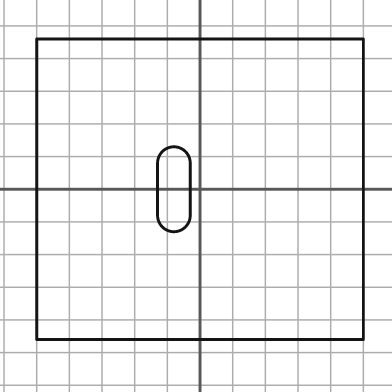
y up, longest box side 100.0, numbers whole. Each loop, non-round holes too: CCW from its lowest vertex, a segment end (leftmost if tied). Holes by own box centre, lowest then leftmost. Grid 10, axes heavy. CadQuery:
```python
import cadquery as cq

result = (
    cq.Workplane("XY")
    .moveTo(-50.0, -46.0)
    .lineTo(50.0, -46.0)
    .lineTo(50.0, 46.0)
    .lineTo(-50.0, 46.0)
    .close()
    .moveTo(-13.0, -8.0)
    .threePointArc((-8.0, -13.0), (-3.0, -8.0))
    .lineTo(-3.0, 8.0)
    .threePointArc((-8.0, 13.0), (-13.0, 8.0))
    .close()
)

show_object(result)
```